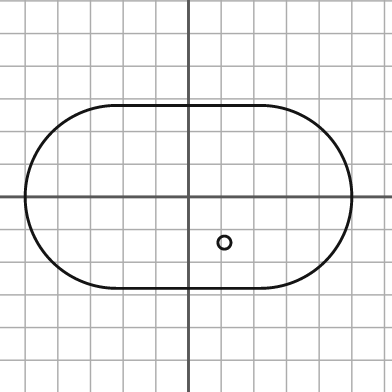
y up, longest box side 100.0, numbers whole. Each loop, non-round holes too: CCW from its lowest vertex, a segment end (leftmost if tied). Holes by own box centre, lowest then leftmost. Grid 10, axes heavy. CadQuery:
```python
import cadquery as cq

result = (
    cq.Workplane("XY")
    .moveTo(-22.0, -28.0)
    .lineTo(22.0, -28.0)
    .threePointArc((50.0, 0.0), (22.0, 28.0))
    .lineTo(-22.0, 28.0)
    .threePointArc((-50.0, 0.0), (-22.0, -28.0))
    .close()
    .moveTo(11.0, -14.0)
    .circle(2.0)
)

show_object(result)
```